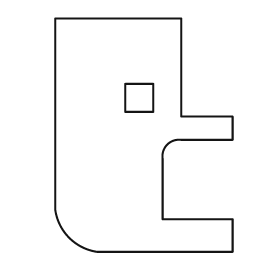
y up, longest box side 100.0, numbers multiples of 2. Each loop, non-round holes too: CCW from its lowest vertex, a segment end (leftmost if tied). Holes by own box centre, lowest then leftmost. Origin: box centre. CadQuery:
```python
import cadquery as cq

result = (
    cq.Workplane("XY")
    .moveTo(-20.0, -50.0)
    .lineTo(38.0, -50.0)
    .lineTo(38.0, -36.0)
    .lineTo(8.0, -36.0)
    .lineTo(8.0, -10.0)
    .threePointArc((10.0, -4.0), (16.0, -2.0))
    .lineTo(38.0, -2.0)
    .lineTo(38.0, 8.0)
    .lineTo(16.0, 8.0)
    .lineTo(16.0, 50.0)
    .lineTo(-38.0, 50.0)
    .lineTo(-38.0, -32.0)
    .threePointArc((-32.0, -44.0), (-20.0, -50.0))
    .close()
    .moveTo(-8.0, 10.0)
    .lineTo(4.0, 10.0)
    .lineTo(4.0, 22.0)
    .lineTo(-8.0, 22.0)
    .close()
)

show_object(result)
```